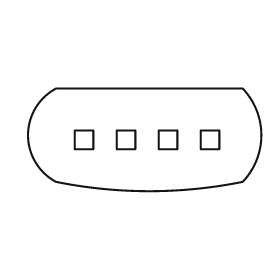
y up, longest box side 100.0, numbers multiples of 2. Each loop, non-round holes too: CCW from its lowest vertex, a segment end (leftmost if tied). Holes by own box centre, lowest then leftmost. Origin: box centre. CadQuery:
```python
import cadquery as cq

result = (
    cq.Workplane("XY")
    .moveTo(-38.0, -18.0)
    .threePointArc((2.0, -22.0), (42.0, -18.0))
    .threePointArc((50.0, 2.0), (42.0, 22.0))
    .lineTo(-38.0, 22.0)
    .threePointArc((-50.0, 2.0), (-38.0, -18.0))
    .close()
    .moveTo(-30.0, -4.0)
    .lineTo(-22.0, -4.0)
    .lineTo(-22.0, 4.0)
    .lineTo(-30.0, 4.0)
    .close()
    .moveTo(-12.0, -4.0)
    .lineTo(-4.0, -4.0)
    .lineTo(-4.0, 4.0)
    .lineTo(-12.0, 4.0)
    .close()
    .moveTo(6.0, -4.0)
    .lineTo(14.0, -4.0)
    .lineTo(14.0, 4.0)
    .lineTo(6.0, 4.0)
    .close()
    .moveTo(24.0, -4.0)
    .lineTo(32.0, -4.0)
    .lineTo(32.0, 4.0)
    .lineTo(24.0, 4.0)
    .close()
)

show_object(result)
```